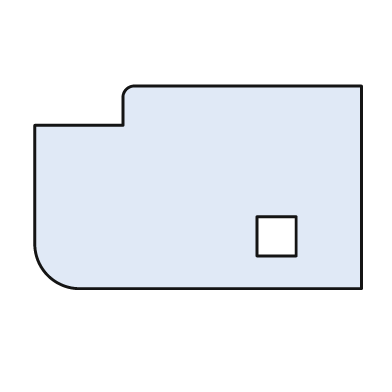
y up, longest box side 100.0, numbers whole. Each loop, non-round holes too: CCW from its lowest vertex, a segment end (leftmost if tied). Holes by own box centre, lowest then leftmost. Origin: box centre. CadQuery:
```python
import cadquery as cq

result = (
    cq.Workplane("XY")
    .moveTo(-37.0, -31.0)
    .lineTo(50.0, -31.0)
    .lineTo(50.0, 31.0)
    .lineTo(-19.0, 31.0)
    .threePointArc((-22.0, 30.0), (-23.0, 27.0))
    .lineTo(-23.0, 19.0)
    .lineTo(-50.0, 19.0)
    .lineTo(-50.0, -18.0)
    .threePointArc((-46.0, -27.0), (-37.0, -31.0))
    .close()
    .moveTo(18.0, -21.0)
    .lineTo(30.0, -21.0)
    .lineTo(30.0, -9.0)
    .lineTo(18.0, -9.0)
    .close()
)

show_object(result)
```